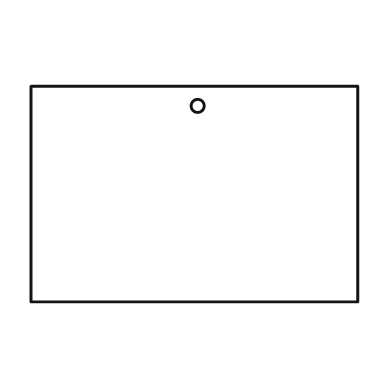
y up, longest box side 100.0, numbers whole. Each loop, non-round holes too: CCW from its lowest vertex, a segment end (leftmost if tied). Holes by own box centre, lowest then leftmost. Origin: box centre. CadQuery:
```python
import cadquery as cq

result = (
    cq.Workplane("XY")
    .moveTo(-50.0, -33.0)
    .lineTo(50.0, -33.0)
    .lineTo(50.0, 33.0)
    .lineTo(-50.0, 33.0)
    .close()
    .moveTo(1.0, 27.0)
    .circle(2.0)
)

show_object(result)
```